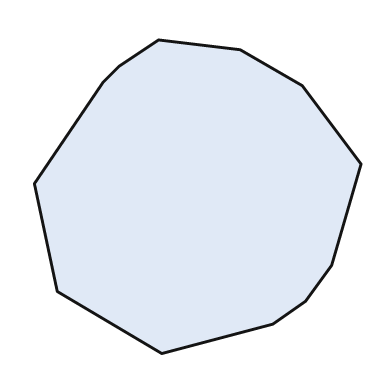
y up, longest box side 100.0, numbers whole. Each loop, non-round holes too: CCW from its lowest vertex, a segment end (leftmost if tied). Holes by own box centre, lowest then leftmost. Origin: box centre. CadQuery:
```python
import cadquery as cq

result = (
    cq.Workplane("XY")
    .moveTo(-11.0, -48.0)
    .lineTo(23.0, -39.0)
    .lineTo(33.0, -32.0)
    .lineTo(41.0, -21.0)
    .lineTo(50.0, 10.0)
    .lineTo(32.0, 34.0)
    .lineTo(13.0, 45.0)
    .lineTo(-12.0, 48.0)
    .lineTo(-24.0, 40.0)
    .lineTo(-29.0, 35.0)
    .lineTo(-50.0, 4.0)
    .lineTo(-43.0, -29.0)
    .close()
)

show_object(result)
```